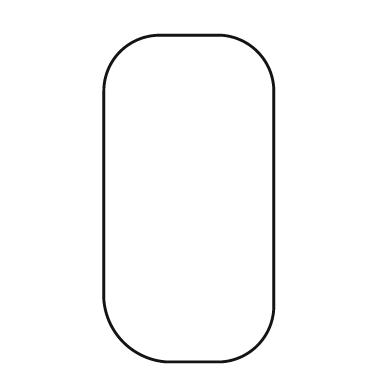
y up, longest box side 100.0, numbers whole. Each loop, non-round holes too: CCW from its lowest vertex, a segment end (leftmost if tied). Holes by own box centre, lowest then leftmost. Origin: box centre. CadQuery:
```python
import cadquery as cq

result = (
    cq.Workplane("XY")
    .moveTo(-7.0, -50.0)
    .lineTo(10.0, -50.0)
    .threePointArc((21.0, -45.0), (26.0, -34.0))
    .lineTo(26.0, 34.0)
    .threePointArc((21.0, 45.0), (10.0, 50.0))
    .lineTo(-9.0, 50.0)
    .threePointArc((-21.0, 45.0), (-26.0, 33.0))
    .lineTo(-26.0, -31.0)
    .threePointArc((-20.0, -44.0), (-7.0, -50.0))
    .close()
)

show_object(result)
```